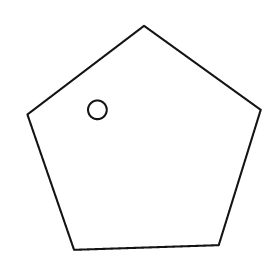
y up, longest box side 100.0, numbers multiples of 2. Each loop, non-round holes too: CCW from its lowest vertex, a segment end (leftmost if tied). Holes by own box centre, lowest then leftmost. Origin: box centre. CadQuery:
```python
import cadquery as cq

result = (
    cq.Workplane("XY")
    .moveTo(-30.0, -48.0)
    .lineTo(32.0, -46.0)
    .lineTo(50.0, 12.0)
    .lineTo(0.0, 48.0)
    .lineTo(-50.0, 10.0)
    .close()
    .moveTo(-20.0, 12.0)
    .circle(4.0)
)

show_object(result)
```